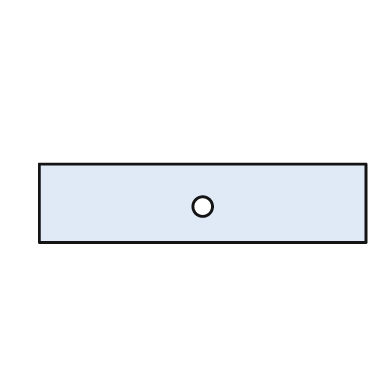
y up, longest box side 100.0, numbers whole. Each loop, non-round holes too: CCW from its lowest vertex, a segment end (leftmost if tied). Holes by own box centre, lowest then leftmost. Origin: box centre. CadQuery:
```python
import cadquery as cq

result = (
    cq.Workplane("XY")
    .moveTo(-50.0, -12.0)
    .lineTo(50.0, -12.0)
    .lineTo(50.0, 12.0)
    .lineTo(-50.0, 12.0)
    .close()
    .moveTo(0.0, -1.0)
    .circle(3.0)
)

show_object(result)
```